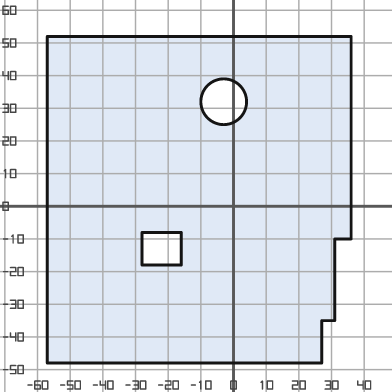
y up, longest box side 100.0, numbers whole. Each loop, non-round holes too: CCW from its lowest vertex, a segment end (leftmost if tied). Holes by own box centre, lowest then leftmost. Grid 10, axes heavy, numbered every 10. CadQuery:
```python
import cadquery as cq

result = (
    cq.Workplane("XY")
    .moveTo(-57.0, -48.0)
    .lineTo(27.0, -48.0)
    .lineTo(27.0, -35.0)
    .lineTo(31.0, -35.0)
    .lineTo(31.0, -10.0)
    .lineTo(36.0, -10.0)
    .lineTo(36.0, 52.0)
    .lineTo(-57.0, 52.0)
    .close()
    .moveTo(-28.0, -18.0)
    .lineTo(-16.0, -18.0)
    .lineTo(-16.0, -8.0)
    .lineTo(-28.0, -8.0)
    .close()
    .moveTo(-3.0, 32.0)
    .circle(7.0)
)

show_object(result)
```